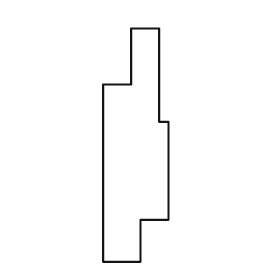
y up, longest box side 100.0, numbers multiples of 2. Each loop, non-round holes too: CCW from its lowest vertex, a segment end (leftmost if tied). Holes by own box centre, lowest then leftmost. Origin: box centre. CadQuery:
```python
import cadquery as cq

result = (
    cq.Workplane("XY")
    .moveTo(-14.0, -50.0)
    .lineTo(2.0, -50.0)
    .lineTo(2.0, -32.0)
    .lineTo(14.0, -32.0)
    .lineTo(14.0, 10.0)
    .lineTo(10.0, 10.0)
    .lineTo(10.0, 50.0)
    .lineTo(-2.0, 50.0)
    .lineTo(-2.0, 26.0)
    .lineTo(-14.0, 26.0)
    .close()
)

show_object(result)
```